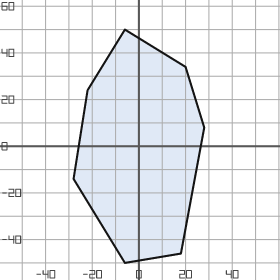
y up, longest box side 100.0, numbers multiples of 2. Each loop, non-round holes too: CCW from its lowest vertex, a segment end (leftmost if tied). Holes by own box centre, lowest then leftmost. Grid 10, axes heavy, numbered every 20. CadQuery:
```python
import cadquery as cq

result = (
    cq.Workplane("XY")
    .moveTo(-6.0, -50.0)
    .lineTo(18.0, -46.0)
    .lineTo(28.0, 8.0)
    .lineTo(20.0, 34.0)
    .lineTo(-6.0, 50.0)
    .lineTo(-22.0, 24.0)
    .lineTo(-28.0, -14.0)
    .close()
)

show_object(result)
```